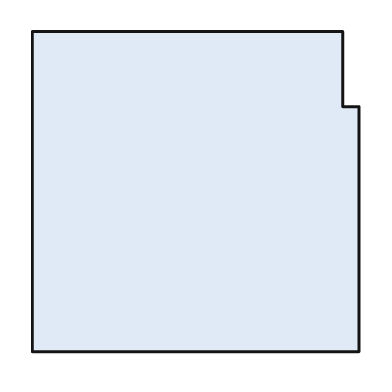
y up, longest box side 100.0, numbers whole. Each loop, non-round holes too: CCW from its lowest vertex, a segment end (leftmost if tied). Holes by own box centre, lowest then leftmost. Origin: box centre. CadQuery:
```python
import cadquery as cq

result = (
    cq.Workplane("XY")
    .moveTo(-50.0, -49.0)
    .lineTo(50.0, -49.0)
    .lineTo(50.0, 26.0)
    .lineTo(45.0, 26.0)
    .lineTo(45.0, 49.0)
    .lineTo(-50.0, 49.0)
    .close()
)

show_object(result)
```